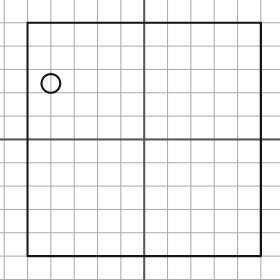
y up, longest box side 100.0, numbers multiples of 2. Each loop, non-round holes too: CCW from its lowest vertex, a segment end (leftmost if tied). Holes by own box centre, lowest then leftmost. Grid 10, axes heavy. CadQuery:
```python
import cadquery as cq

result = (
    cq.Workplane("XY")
    .moveTo(-50.0, -50.0)
    .lineTo(50.0, -50.0)
    .lineTo(50.0, 50.0)
    .lineTo(-50.0, 50.0)
    .close()
    .moveTo(-40.0, 24.0)
    .circle(4.0)
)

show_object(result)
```